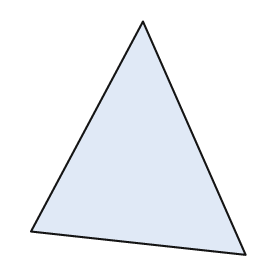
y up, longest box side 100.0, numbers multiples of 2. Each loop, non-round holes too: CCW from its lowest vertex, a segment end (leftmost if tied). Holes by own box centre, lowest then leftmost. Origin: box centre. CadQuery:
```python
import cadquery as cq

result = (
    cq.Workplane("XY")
    .moveTo(46.0, -50.0)
    .lineTo(2.0, 50.0)
    .lineTo(-46.0, -40.0)
    .close()
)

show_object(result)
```